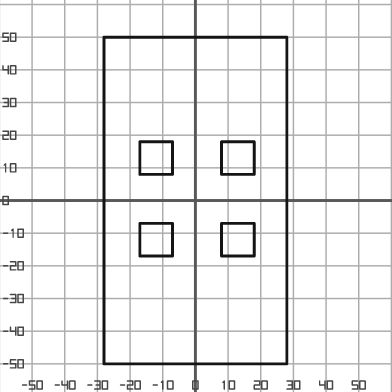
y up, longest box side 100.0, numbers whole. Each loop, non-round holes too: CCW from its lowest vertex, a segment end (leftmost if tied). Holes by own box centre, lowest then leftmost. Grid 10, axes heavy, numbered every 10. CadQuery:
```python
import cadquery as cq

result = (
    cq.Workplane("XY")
    .moveTo(-28.0, -50.0)
    .lineTo(28.0, -50.0)
    .lineTo(28.0, 50.0)
    .lineTo(-28.0, 50.0)
    .close()
    .moveTo(-17.0, -17.0)
    .lineTo(-7.0, -17.0)
    .lineTo(-7.0, -7.0)
    .lineTo(-17.0, -7.0)
    .close()
    .moveTo(8.0, -17.0)
    .lineTo(18.0, -17.0)
    .lineTo(18.0, -7.0)
    .lineTo(8.0, -7.0)
    .close()
    .moveTo(-17.0, 8.0)
    .lineTo(-7.0, 8.0)
    .lineTo(-7.0, 18.0)
    .lineTo(-17.0, 18.0)
    .close()
    .moveTo(8.0, 8.0)
    .lineTo(18.0, 8.0)
    .lineTo(18.0, 18.0)
    .lineTo(8.0, 18.0)
    .close()
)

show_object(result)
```